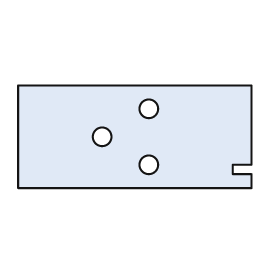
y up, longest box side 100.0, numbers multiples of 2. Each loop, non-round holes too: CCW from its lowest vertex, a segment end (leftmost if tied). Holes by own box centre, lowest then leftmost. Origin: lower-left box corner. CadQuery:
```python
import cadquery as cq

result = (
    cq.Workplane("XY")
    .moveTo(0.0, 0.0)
    .lineTo(100.0, 0.0)
    .lineTo(100.0, 6.0)
    .lineTo(92.0, 6.0)
    .lineTo(92.0, 10.0)
    .lineTo(100.0, 10.0)
    .lineTo(100.0, 44.0)
    .lineTo(0.0, 44.0)
    .close()
    .moveTo(56.0, 10.0)
    .circle(4.0)
    .moveTo(36.0, 22.0)
    .circle(4.0)
    .moveTo(56.0, 34.0)
    .circle(4.0)
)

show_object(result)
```